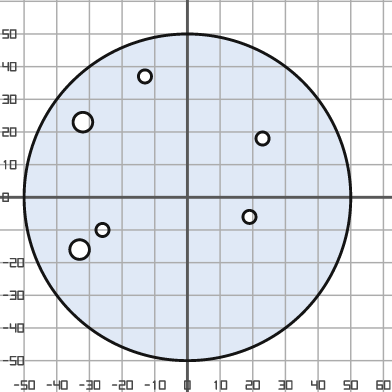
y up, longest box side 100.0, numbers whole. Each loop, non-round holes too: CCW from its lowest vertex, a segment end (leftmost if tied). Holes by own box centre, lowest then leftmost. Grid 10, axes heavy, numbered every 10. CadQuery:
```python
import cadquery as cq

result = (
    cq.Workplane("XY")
    .moveTo(0.0, 0.0)
    .circle(50.0)
    .moveTo(-33.0, -16.0)
    .circle(3.0)
    .moveTo(-26.0, -10.0)
    .circle(2.0)
    .moveTo(19.0, -6.0)
    .circle(2.0)
    .moveTo(23.0, 18.0)
    .circle(2.0)
    .moveTo(-32.0, 23.0)
    .circle(3.0)
    .moveTo(-13.0, 37.0)
    .circle(2.0)
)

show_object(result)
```